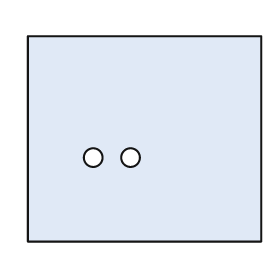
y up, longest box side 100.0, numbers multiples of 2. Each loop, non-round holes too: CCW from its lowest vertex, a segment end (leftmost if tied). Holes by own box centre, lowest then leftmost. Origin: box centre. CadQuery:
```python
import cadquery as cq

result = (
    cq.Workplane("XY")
    .moveTo(-50.0, -44.0)
    .lineTo(50.0, -44.0)
    .lineTo(50.0, 44.0)
    .lineTo(-50.0, 44.0)
    .close()
    .moveTo(-22.0, -8.0)
    .circle(4.0)
    .moveTo(-6.0, -8.0)
    .circle(4.0)
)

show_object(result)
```